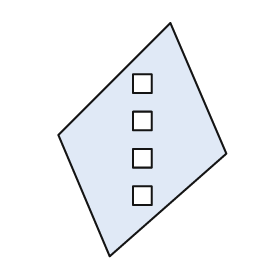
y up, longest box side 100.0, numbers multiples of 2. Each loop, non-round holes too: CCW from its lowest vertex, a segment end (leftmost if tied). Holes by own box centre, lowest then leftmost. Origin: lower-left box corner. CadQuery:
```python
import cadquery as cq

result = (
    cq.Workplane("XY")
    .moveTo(22.0, 0.0)
    .lineTo(72.0, 44.0)
    .lineTo(48.0, 100.0)
    .lineTo(0.0, 52.0)
    .close()
    .moveTo(32.0, 22.0)
    .lineTo(40.0, 22.0)
    .lineTo(40.0, 30.0)
    .lineTo(32.0, 30.0)
    .close()
    .moveTo(32.0, 38.0)
    .lineTo(40.0, 38.0)
    .lineTo(40.0, 46.0)
    .lineTo(32.0, 46.0)
    .close()
    .moveTo(32.0, 54.0)
    .lineTo(40.0, 54.0)
    .lineTo(40.0, 62.0)
    .lineTo(32.0, 62.0)
    .close()
    .moveTo(32.0, 70.0)
    .lineTo(40.0, 70.0)
    .lineTo(40.0, 78.0)
    .lineTo(32.0, 78.0)
    .close()
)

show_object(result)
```